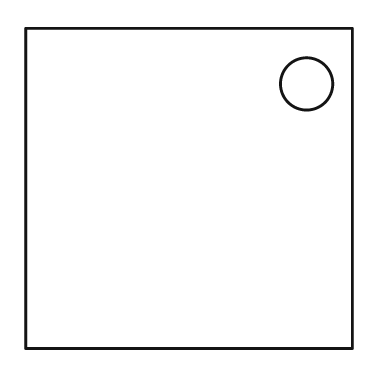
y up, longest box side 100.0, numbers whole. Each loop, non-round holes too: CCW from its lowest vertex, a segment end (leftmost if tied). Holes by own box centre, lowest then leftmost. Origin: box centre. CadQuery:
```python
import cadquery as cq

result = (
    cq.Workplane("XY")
    .moveTo(-50.0, -49.0)
    .lineTo(50.0, -49.0)
    .lineTo(50.0, 49.0)
    .lineTo(-50.0, 49.0)
    .close()
    .moveTo(36.0, 32.0)
    .circle(8.0)
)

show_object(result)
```